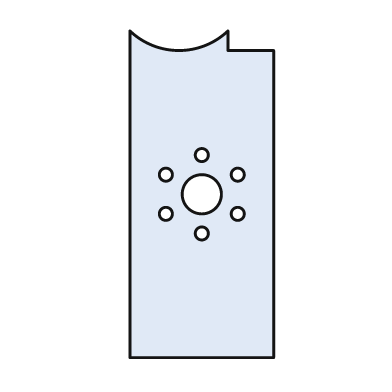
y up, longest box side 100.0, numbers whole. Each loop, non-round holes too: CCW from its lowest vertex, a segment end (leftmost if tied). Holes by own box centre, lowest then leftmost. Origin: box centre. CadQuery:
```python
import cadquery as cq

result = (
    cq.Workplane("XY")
    .moveTo(-22.0, -50.0)
    .lineTo(22.0, -50.0)
    .lineTo(22.0, 44.0)
    .lineTo(8.0, 44.0)
    .lineTo(8.0, 50.0)
    .threePointArc((-7.0, 44.0), (-22.0, 50.0))
    .close()
    .moveTo(0.0, -12.0)
    .circle(2.0)
    .moveTo(-11.0, -6.0)
    .circle(2.0)
    .moveTo(11.0, -6.0)
    .circle(2.0)
    .moveTo(0.0, 0.0)
    .circle(6.0)
    .moveTo(-11.0, 6.0)
    .circle(2.0)
    .moveTo(11.0, 6.0)
    .circle(2.0)
    .moveTo(0.0, 12.0)
    .circle(2.0)
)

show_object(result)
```